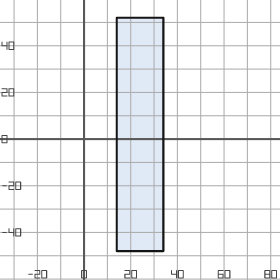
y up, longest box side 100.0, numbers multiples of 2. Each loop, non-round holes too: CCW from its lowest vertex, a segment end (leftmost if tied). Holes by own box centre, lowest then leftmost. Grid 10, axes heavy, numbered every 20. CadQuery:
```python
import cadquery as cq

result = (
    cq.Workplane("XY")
    .moveTo(14.0, -48.0)
    .lineTo(34.0, -48.0)
    .lineTo(34.0, 52.0)
    .lineTo(14.0, 52.0)
    .close()
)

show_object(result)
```